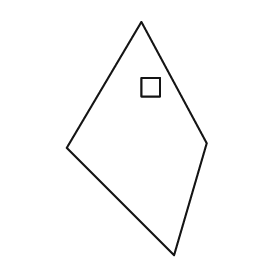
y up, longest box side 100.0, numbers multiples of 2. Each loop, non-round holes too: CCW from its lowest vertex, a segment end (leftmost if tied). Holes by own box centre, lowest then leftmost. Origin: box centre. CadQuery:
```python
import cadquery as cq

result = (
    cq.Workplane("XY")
    .moveTo(16.0, -50.0)
    .lineTo(30.0, -2.0)
    .lineTo(2.0, 50.0)
    .lineTo(-30.0, -4.0)
    .close()
    .moveTo(2.0, 18.0)
    .lineTo(10.0, 18.0)
    .lineTo(10.0, 26.0)
    .lineTo(2.0, 26.0)
    .close()
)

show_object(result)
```